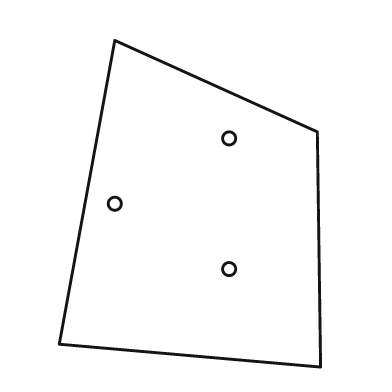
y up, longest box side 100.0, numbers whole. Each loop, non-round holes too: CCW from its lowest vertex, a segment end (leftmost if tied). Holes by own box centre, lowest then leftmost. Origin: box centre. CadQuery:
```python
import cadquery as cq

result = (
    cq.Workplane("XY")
    .moveTo(40.0, -50.0)
    .lineTo(39.0, 22.0)
    .lineTo(-23.0, 50.0)
    .lineTo(-40.0, -43.0)
    .close()
    .moveTo(12.0, -20.0)
    .circle(2.0)
    .moveTo(-23.0, 0.0)
    .circle(2.0)
    .moveTo(12.0, 20.0)
    .circle(2.0)
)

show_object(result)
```